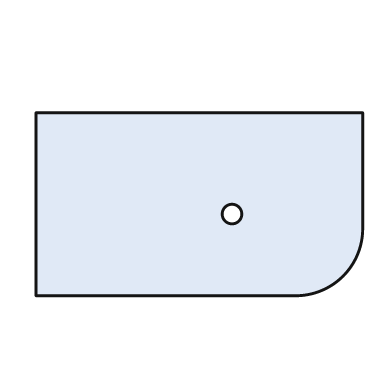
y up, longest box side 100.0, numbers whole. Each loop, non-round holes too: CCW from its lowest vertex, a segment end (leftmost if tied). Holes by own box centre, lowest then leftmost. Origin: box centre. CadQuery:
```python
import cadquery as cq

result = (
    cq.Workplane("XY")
    .moveTo(-50.0, -28.0)
    .lineTo(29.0, -28.0)
    .threePointArc((44.0, -22.0), (50.0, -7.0))
    .lineTo(50.0, 28.0)
    .lineTo(-50.0, 28.0)
    .close()
    .moveTo(10.0, -3.0)
    .circle(3.0)
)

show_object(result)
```